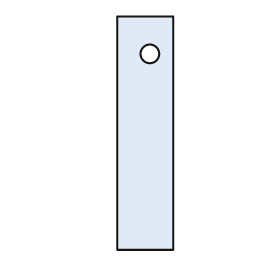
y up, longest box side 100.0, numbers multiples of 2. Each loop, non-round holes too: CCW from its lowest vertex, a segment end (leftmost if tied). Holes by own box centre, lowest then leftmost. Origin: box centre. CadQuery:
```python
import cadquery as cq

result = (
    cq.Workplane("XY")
    .moveTo(-12.0, -50.0)
    .lineTo(12.0, -50.0)
    .lineTo(12.0, 50.0)
    .lineTo(-12.0, 50.0)
    .close()
    .moveTo(2.0, 34.0)
    .circle(4.0)
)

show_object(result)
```